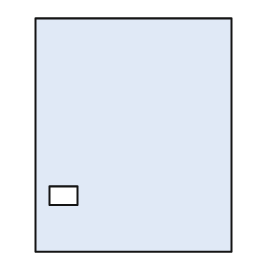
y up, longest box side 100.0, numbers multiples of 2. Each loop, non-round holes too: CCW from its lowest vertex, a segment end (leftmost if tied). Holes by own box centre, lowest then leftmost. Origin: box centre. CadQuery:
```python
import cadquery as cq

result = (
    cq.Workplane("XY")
    .moveTo(-42.0, -50.0)
    .lineTo(42.0, -50.0)
    .lineTo(42.0, 50.0)
    .lineTo(-42.0, 50.0)
    .close()
    .moveTo(-36.0, -30.0)
    .lineTo(-24.0, -30.0)
    .lineTo(-24.0, -22.0)
    .lineTo(-36.0, -22.0)
    .close()
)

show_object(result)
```